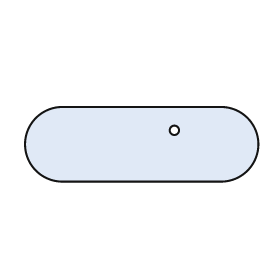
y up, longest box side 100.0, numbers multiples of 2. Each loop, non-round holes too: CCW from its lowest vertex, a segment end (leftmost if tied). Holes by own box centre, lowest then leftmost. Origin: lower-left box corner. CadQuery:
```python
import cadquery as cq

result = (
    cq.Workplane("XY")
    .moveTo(16.0, 0.0)
    .lineTo(84.0, 0.0)
    .threePointArc((100.0, 16.0), (84.0, 32.0))
    .lineTo(16.0, 32.0)
    .threePointArc((0.0, 16.0), (16.0, 0.0))
    .close()
    .moveTo(64.0, 22.0)
    .circle(2.0)
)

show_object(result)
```